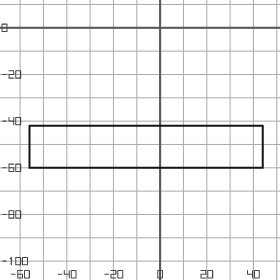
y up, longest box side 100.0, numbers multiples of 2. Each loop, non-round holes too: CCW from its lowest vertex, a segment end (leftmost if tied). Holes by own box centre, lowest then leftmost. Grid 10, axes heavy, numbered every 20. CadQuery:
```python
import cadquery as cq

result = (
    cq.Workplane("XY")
    .moveTo(-56.0, -60.0)
    .lineTo(44.0, -60.0)
    .lineTo(44.0, -42.0)
    .lineTo(-56.0, -42.0)
    .close()
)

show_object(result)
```